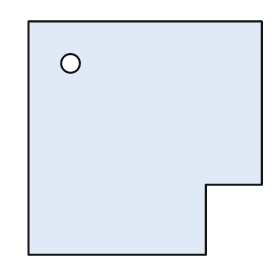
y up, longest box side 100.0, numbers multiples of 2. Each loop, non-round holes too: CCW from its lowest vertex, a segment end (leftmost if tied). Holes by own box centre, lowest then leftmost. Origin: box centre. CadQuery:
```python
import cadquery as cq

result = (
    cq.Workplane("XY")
    .moveTo(-50.0, -50.0)
    .lineTo(26.0, -50.0)
    .lineTo(26.0, -20.0)
    .lineTo(50.0, -20.0)
    .lineTo(50.0, 50.0)
    .lineTo(-50.0, 50.0)
    .close()
    .moveTo(-32.0, 32.0)
    .circle(4.0)
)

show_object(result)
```